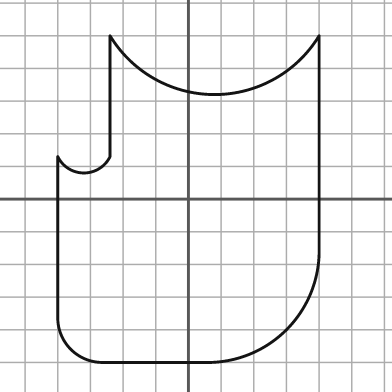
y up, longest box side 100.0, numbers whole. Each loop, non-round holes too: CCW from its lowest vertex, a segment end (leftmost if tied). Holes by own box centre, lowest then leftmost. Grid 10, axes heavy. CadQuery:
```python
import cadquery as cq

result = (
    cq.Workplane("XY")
    .moveTo(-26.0, -50.0)
    .lineTo(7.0, -50.0)
    .threePointArc((30.0, -40.0), (40.0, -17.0))
    .lineTo(40.0, 50.0)
    .threePointArc((8.0, 32.0), (-24.0, 50.0))
    .lineTo(-24.0, 13.0)
    .threePointArc((-32.0, 8.0), (-40.0, 13.0))
    .lineTo(-40.0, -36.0)
    .threePointArc((-36.0, -46.0), (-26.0, -50.0))
    .close()
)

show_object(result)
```